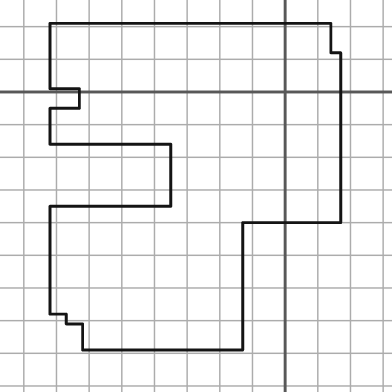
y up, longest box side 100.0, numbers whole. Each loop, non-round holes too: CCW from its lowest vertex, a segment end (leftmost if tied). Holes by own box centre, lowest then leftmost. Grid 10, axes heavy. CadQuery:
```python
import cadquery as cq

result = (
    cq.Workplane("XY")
    .moveTo(-62.0, -79.0)
    .lineTo(-13.0, -79.0)
    .lineTo(-13.0, -40.0)
    .lineTo(17.0, -40.0)
    .lineTo(17.0, 12.0)
    .lineTo(14.0, 12.0)
    .lineTo(14.0, 21.0)
    .lineTo(-72.0, 21.0)
    .lineTo(-72.0, 1.0)
    .lineTo(-63.0, 1.0)
    .lineTo(-63.0, -5.0)
    .lineTo(-72.0, -5.0)
    .lineTo(-72.0, -16.0)
    .lineTo(-35.0, -16.0)
    .lineTo(-35.0, -35.0)
    .lineTo(-72.0, -35.0)
    .lineTo(-72.0, -68.0)
    .lineTo(-67.0, -68.0)
    .lineTo(-67.0, -71.0)
    .lineTo(-62.0, -71.0)
    .close()
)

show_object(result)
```